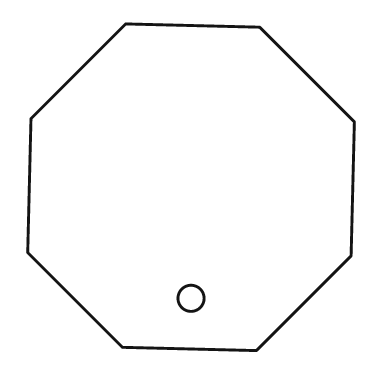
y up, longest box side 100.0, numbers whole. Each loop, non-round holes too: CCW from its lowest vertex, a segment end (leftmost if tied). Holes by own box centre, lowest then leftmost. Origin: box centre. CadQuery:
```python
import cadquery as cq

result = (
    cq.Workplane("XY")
    .moveTo(20.0, -50.0)
    .lineTo(49.0, -21.0)
    .lineTo(50.0, 20.0)
    .lineTo(21.0, 49.0)
    .lineTo(-20.0, 50.0)
    .lineTo(-49.0, 21.0)
    .lineTo(-50.0, -20.0)
    .lineTo(-21.0, -49.0)
    .close()
    .moveTo(0.0, -34.0)
    .circle(4.0)
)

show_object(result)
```